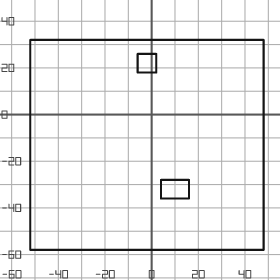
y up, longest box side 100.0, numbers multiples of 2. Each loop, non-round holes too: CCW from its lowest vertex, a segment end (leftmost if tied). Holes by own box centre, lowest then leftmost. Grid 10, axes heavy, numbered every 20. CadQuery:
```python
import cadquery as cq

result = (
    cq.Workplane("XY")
    .moveTo(-52.0, -58.0)
    .lineTo(48.0, -58.0)
    .lineTo(48.0, 32.0)
    .lineTo(-52.0, 32.0)
    .close()
    .moveTo(4.0, -36.0)
    .lineTo(16.0, -36.0)
    .lineTo(16.0, -28.0)
    .lineTo(4.0, -28.0)
    .close()
    .moveTo(-6.0, 18.0)
    .lineTo(2.0, 18.0)
    .lineTo(2.0, 26.0)
    .lineTo(-6.0, 26.0)
    .close()
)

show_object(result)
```